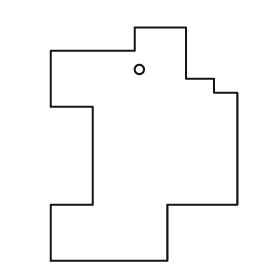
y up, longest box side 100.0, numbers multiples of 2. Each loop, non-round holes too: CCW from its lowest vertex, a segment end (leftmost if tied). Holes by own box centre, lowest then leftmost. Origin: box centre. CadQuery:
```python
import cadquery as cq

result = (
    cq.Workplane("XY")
    .moveTo(-40.0, -50.0)
    .lineTo(10.0, -50.0)
    .lineTo(10.0, -26.0)
    .lineTo(40.0, -26.0)
    .lineTo(40.0, 22.0)
    .lineTo(30.0, 22.0)
    .lineTo(30.0, 28.0)
    .lineTo(18.0, 28.0)
    .lineTo(18.0, 50.0)
    .lineTo(-4.0, 50.0)
    .lineTo(-4.0, 40.0)
    .lineTo(-40.0, 40.0)
    .lineTo(-40.0, 16.0)
    .lineTo(-22.0, 16.0)
    .lineTo(-22.0, -26.0)
    .lineTo(-40.0, -26.0)
    .close()
    .moveTo(-2.0, 32.0)
    .circle(2.0)
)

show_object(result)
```